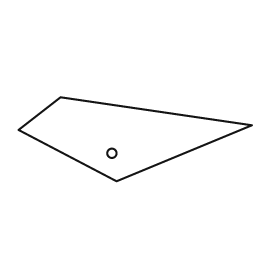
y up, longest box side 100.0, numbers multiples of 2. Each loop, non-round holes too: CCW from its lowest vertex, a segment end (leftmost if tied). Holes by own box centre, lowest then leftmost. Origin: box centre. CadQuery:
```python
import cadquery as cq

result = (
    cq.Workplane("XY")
    .moveTo(-8.0, -18.0)
    .lineTo(50.0, 6.0)
    .lineTo(-32.0, 18.0)
    .lineTo(-50.0, 4.0)
    .close()
    .moveTo(-10.0, -6.0)
    .circle(2.0)
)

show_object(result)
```